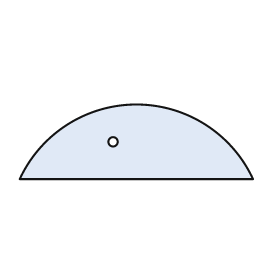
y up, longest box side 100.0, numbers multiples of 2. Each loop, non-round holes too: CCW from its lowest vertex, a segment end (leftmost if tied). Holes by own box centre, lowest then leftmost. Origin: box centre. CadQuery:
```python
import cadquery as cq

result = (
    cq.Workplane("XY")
    .moveTo(-50.0, -16.0)
    .lineTo(50.0, -16.0)
    .threePointArc((0.0, 16.0), (-50.0, -16.0))
    .close()
    .moveTo(-10.0, 0.0)
    .circle(2.0)
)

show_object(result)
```